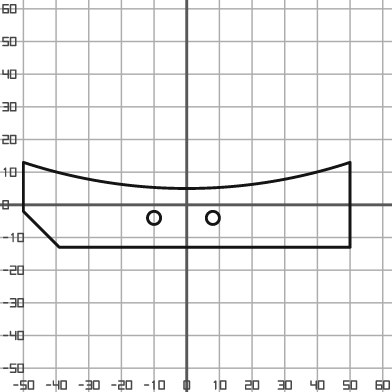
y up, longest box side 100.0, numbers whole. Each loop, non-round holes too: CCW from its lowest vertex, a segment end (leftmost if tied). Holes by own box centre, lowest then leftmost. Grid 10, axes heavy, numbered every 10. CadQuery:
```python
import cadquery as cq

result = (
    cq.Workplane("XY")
    .moveTo(-39.0, -13.0)
    .lineTo(50.0, -13.0)
    .lineTo(50.0, 13.0)
    .threePointArc((0.0, 5.0), (-50.0, 13.0))
    .lineTo(-50.0, -2.0)
    .close()
    .moveTo(-10.0, -4.0)
    .circle(2.0)
    .moveTo(8.0, -4.0)
    .circle(2.0)
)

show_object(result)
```